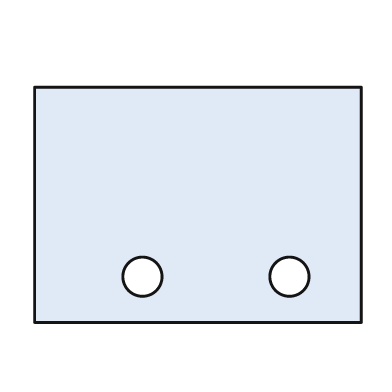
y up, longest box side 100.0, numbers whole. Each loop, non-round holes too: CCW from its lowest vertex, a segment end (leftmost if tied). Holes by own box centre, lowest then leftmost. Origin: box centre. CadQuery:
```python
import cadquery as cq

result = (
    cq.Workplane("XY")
    .moveTo(-50.0, -36.0)
    .lineTo(50.0, -36.0)
    .lineTo(50.0, 36.0)
    .lineTo(-50.0, 36.0)
    .close()
    .moveTo(-17.0, -22.0)
    .circle(6.0)
    .moveTo(28.0, -22.0)
    .circle(6.0)
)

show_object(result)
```